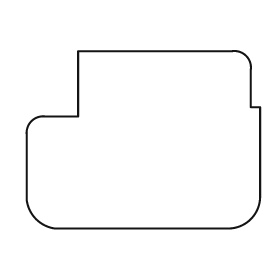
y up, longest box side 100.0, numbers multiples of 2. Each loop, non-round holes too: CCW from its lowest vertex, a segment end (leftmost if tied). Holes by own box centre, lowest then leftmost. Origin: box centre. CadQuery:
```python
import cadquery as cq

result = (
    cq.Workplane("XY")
    .moveTo(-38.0, -38.0)
    .lineTo(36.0, -38.0)
    .threePointArc((46.0, -34.0), (50.0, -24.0))
    .lineTo(50.0, 14.0)
    .lineTo(46.0, 14.0)
    .lineTo(46.0, 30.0)
    .threePointArc((44.0, 36.0), (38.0, 38.0))
    .lineTo(-28.0, 38.0)
    .lineTo(-28.0, 10.0)
    .lineTo(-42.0, 10.0)
    .threePointArc((-48.0, 8.0), (-50.0, 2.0))
    .lineTo(-50.0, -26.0)
    .threePointArc((-46.0, -34.0), (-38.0, -38.0))
    .close()
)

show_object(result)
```